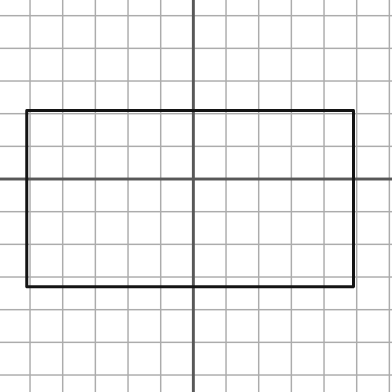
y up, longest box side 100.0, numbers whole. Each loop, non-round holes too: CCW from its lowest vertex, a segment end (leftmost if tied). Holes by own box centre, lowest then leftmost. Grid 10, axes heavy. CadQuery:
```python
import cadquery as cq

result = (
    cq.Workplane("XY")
    .moveTo(-51.0, -33.0)
    .lineTo(49.0, -33.0)
    .lineTo(49.0, 21.0)
    .lineTo(-51.0, 21.0)
    .close()
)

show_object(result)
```